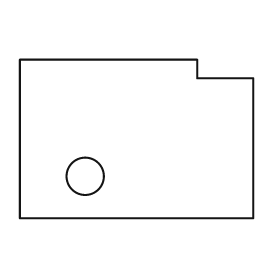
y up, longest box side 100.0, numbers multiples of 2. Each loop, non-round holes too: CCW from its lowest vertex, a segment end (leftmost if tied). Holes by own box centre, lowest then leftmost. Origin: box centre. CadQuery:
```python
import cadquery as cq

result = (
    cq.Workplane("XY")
    .moveTo(-50.0, -34.0)
    .lineTo(50.0, -34.0)
    .lineTo(50.0, 26.0)
    .lineTo(26.0, 26.0)
    .lineTo(26.0, 34.0)
    .lineTo(-50.0, 34.0)
    .close()
    .moveTo(-22.0, -16.0)
    .circle(8.0)
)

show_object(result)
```